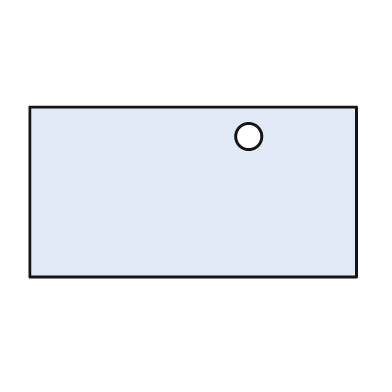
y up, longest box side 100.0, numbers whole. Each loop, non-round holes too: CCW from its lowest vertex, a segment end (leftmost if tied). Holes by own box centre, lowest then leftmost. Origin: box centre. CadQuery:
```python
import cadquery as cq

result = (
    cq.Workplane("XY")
    .moveTo(-50.0, -26.0)
    .lineTo(50.0, -26.0)
    .lineTo(50.0, 26.0)
    .lineTo(-50.0, 26.0)
    .close()
    .moveTo(17.0, 17.0)
    .circle(4.0)
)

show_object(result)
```